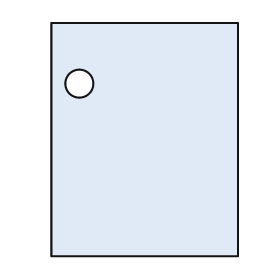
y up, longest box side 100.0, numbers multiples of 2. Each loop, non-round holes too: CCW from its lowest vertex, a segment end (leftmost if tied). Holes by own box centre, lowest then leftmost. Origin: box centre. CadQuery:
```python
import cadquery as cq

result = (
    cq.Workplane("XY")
    .moveTo(-40.0, -50.0)
    .lineTo(40.0, -50.0)
    .lineTo(40.0, 50.0)
    .lineTo(-40.0, 50.0)
    .close()
    .moveTo(-28.0, 24.0)
    .circle(6.0)
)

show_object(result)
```